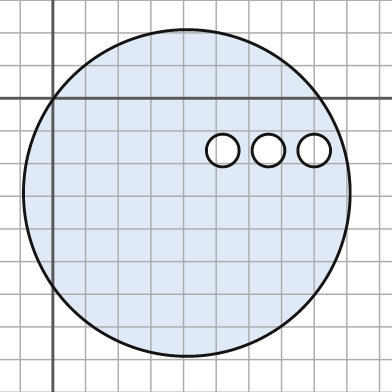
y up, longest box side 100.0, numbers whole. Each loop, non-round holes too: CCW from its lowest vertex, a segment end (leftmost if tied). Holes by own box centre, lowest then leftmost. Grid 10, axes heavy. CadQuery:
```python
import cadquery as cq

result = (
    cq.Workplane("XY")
    .moveTo(41.0, -29.0)
    .circle(50.0)
    .moveTo(52.0, -16.0)
    .circle(5.0)
    .moveTo(66.0, -16.0)
    .circle(5.0)
    .moveTo(80.0, -16.0)
    .circle(5.0)
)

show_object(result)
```